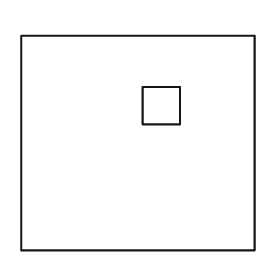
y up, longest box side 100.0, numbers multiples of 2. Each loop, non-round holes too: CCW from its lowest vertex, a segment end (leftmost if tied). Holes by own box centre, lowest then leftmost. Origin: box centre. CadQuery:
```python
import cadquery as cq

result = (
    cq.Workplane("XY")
    .moveTo(-50.0, -46.0)
    .lineTo(50.0, -46.0)
    .lineTo(50.0, 46.0)
    .lineTo(-50.0, 46.0)
    .close()
    .moveTo(2.0, 8.0)
    .lineTo(18.0, 8.0)
    .lineTo(18.0, 24.0)
    .lineTo(2.0, 24.0)
    .close()
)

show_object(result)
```